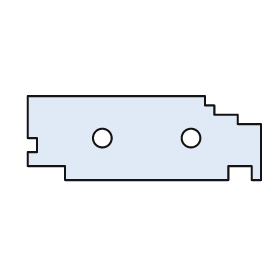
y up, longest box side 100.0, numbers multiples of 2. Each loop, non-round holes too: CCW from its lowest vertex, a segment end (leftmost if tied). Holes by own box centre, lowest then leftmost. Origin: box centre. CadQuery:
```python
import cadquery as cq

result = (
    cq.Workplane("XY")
    .moveTo(-34.0, -18.0)
    .lineTo(36.0, -18.0)
    .lineTo(36.0, -12.0)
    .lineTo(46.0, -12.0)
    .lineTo(46.0, -18.0)
    .lineTo(50.0, -18.0)
    .lineTo(50.0, 6.0)
    .lineTo(40.0, 6.0)
    .lineTo(40.0, 10.0)
    .lineTo(30.0, 10.0)
    .lineTo(30.0, 14.0)
    .lineTo(26.0, 14.0)
    .lineTo(26.0, 18.0)
    .lineTo(-50.0, 18.0)
    .lineTo(-50.0, 0.0)
    .lineTo(-46.0, 0.0)
    .lineTo(-46.0, -6.0)
    .lineTo(-50.0, -6.0)
    .lineTo(-50.0, -12.0)
    .lineTo(-34.0, -12.0)
    .close()
    .moveTo(-18.0, 0.0)
    .circle(4.0)
    .moveTo(20.0, 0.0)
    .circle(4.0)
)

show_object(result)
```